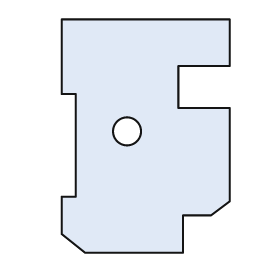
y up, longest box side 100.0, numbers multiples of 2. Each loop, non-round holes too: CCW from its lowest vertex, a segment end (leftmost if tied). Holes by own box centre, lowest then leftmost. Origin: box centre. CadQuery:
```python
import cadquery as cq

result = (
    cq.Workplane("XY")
    .moveTo(-26.0, -50.0)
    .lineTo(16.0, -50.0)
    .lineTo(16.0, -34.0)
    .lineTo(28.0, -34.0)
    .lineTo(36.0, -28.0)
    .lineTo(36.0, 12.0)
    .lineTo(14.0, 12.0)
    .lineTo(14.0, 30.0)
    .lineTo(36.0, 30.0)
    .lineTo(36.0, 50.0)
    .lineTo(-36.0, 50.0)
    .lineTo(-36.0, 18.0)
    .lineTo(-30.0, 18.0)
    .lineTo(-30.0, -26.0)
    .lineTo(-36.0, -26.0)
    .lineTo(-36.0, -42.0)
    .close()
    .moveTo(-8.0, 2.0)
    .circle(6.0)
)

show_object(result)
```